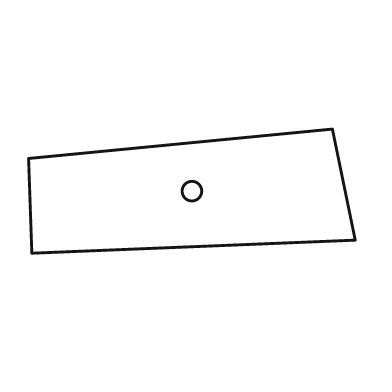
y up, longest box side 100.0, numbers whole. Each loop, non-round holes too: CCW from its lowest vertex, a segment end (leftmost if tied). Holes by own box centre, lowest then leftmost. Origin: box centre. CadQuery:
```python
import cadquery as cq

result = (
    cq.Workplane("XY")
    .moveTo(-49.0, -19.0)
    .lineTo(50.0, -15.0)
    .lineTo(43.0, 19.0)
    .lineTo(-50.0, 10.0)
    .close()
    .moveTo(0.0, 0.0)
    .circle(3.0)
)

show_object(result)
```